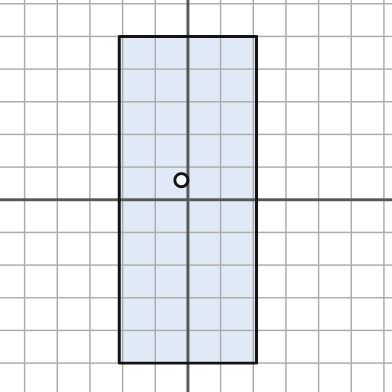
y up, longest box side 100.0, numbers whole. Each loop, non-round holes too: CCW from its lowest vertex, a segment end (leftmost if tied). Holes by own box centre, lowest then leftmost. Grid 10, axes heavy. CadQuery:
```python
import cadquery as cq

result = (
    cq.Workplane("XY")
    .moveTo(-21.0, -50.0)
    .lineTo(21.0, -50.0)
    .lineTo(21.0, 50.0)
    .lineTo(-21.0, 50.0)
    .close()
    .moveTo(-2.0, 6.0)
    .circle(2.0)
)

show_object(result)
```